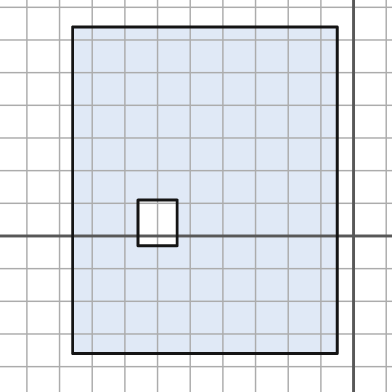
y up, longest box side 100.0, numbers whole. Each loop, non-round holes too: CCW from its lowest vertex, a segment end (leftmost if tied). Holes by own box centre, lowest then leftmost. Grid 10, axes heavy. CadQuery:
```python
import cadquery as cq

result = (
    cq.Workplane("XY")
    .moveTo(-86.0, -36.0)
    .lineTo(-5.0, -36.0)
    .lineTo(-5.0, 64.0)
    .lineTo(-86.0, 64.0)
    .close()
    .moveTo(-66.0, -3.0)
    .lineTo(-54.0, -3.0)
    .lineTo(-54.0, 11.0)
    .lineTo(-66.0, 11.0)
    .close()
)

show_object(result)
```